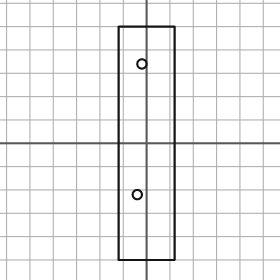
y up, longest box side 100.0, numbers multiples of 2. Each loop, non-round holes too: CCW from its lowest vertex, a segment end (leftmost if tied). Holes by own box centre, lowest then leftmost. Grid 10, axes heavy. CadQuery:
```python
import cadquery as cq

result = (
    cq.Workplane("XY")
    .moveTo(-12.0, -50.0)
    .lineTo(12.0, -50.0)
    .lineTo(12.0, 50.0)
    .lineTo(-12.0, 50.0)
    .close()
    .moveTo(-4.0, -22.0)
    .circle(2.0)
    .moveTo(-2.0, 34.0)
    .circle(2.0)
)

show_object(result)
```